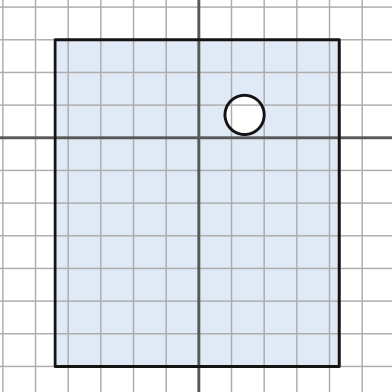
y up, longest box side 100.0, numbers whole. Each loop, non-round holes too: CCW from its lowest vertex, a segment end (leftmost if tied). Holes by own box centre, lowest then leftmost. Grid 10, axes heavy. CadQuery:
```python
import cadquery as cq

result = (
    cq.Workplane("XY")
    .moveTo(-44.0, -70.0)
    .lineTo(43.0, -70.0)
    .lineTo(43.0, 30.0)
    .lineTo(-44.0, 30.0)
    .close()
    .moveTo(14.0, 7.0)
    .circle(6.0)
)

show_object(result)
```